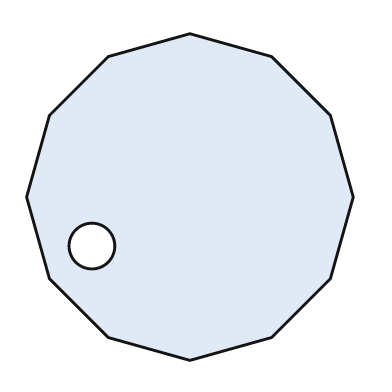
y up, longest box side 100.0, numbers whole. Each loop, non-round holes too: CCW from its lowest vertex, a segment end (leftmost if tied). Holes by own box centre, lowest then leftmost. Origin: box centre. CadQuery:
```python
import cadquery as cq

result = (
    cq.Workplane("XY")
    .moveTo(0.0, -50.0)
    .lineTo(25.0, -43.0)
    .lineTo(43.0, -25.0)
    .lineTo(50.0, 0.0)
    .lineTo(43.0, 25.0)
    .lineTo(25.0, 43.0)
    .lineTo(0.0, 50.0)
    .lineTo(-25.0, 43.0)
    .lineTo(-43.0, 25.0)
    .lineTo(-50.0, 0.0)
    .lineTo(-43.0, -25.0)
    .lineTo(-25.0, -43.0)
    .close()
    .moveTo(-30.0, -15.0)
    .circle(7.0)
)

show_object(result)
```